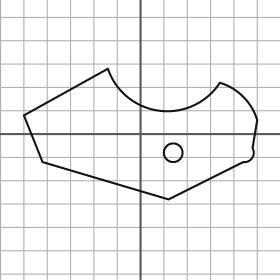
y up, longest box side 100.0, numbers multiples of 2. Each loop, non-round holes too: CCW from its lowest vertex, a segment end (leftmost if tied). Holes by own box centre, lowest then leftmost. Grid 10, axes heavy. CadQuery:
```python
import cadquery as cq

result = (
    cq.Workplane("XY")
    .moveTo(12.0, -28.0)
    .lineTo(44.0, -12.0)
    .threePointArc((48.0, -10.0), (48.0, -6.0))
    .lineTo(50.0, 6.0)
    .threePointArc((44.0, 16.0), (34.0, 22.0))
    .threePointArc((8.0, 10.0), (-14.0, 28.0))
    .lineTo(-50.0, 8.0)
    .lineTo(-42.0, -12.0)
    .close()
    .moveTo(14.0, -8.0)
    .circle(4.0)
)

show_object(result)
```